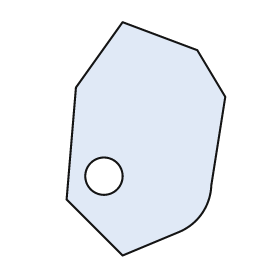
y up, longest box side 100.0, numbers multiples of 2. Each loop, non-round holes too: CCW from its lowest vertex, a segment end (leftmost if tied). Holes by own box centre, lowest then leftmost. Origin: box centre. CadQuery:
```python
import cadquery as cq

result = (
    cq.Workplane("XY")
    .moveTo(-10.0, -50.0)
    .lineTo(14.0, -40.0)
    .threePointArc((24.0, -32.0), (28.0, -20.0))
    .lineTo(34.0, 18.0)
    .lineTo(22.0, 38.0)
    .lineTo(-10.0, 50.0)
    .lineTo(-30.0, 22.0)
    .lineTo(-34.0, -26.0)
    .close()
    .moveTo(-18.0, -16.0)
    .circle(8.0)
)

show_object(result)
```